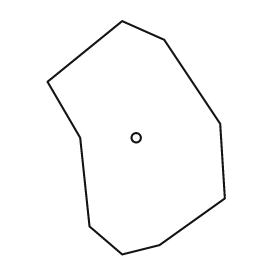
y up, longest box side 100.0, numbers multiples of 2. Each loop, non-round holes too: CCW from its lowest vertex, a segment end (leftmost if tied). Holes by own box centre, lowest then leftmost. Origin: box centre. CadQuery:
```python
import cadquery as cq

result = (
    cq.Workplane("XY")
    .moveTo(-6.0, -50.0)
    .lineTo(10.0, -46.0)
    .lineTo(38.0, -26.0)
    .lineTo(36.0, 6.0)
    .lineTo(12.0, 42.0)
    .lineTo(-6.0, 50.0)
    .lineTo(-38.0, 24.0)
    .lineTo(-24.0, 0.0)
    .lineTo(-20.0, -38.0)
    .close()
    .moveTo(0.0, 0.0)
    .circle(2.0)
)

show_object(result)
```